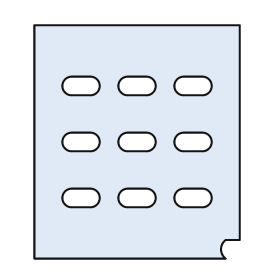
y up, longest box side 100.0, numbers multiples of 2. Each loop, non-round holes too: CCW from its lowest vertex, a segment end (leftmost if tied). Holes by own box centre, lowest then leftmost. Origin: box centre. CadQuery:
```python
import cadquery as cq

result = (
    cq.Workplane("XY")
    .moveTo(-44.0, -50.0)
    .lineTo(38.0, -50.0)
    .threePointArc((36.0, -46.0), (38.0, -42.0))
    .lineTo(44.0, -42.0)
    .lineTo(44.0, 50.0)
    .lineTo(-44.0, 50.0)
    .close()
    .moveTo(-28.0, -28.0)
    .lineTo(-20.0, -28.0)
    .threePointArc((-16.0, -24.0), (-20.0, -20.0))
    .lineTo(-28.0, -20.0)
    .threePointArc((-32.0, -24.0), (-28.0, -28.0))
    .close()
    .moveTo(-4.0, -28.0)
    .lineTo(4.0, -28.0)
    .threePointArc((8.0, -24.0), (4.0, -20.0))
    .lineTo(-4.0, -20.0)
    .threePointArc((-8.0, -24.0), (-4.0, -28.0))
    .close()
    .moveTo(20.0, -28.0)
    .lineTo(28.0, -28.0)
    .threePointArc((32.0, -24.0), (28.0, -20.0))
    .lineTo(20.0, -20.0)
    .threePointArc((16.0, -24.0), (20.0, -28.0))
    .close()
    .moveTo(-28.0, -4.0)
    .lineTo(-20.0, -4.0)
    .threePointArc((-16.0, 0.0), (-20.0, 4.0))
    .lineTo(-28.0, 4.0)
    .threePointArc((-32.0, 0.0), (-28.0, -4.0))
    .close()
    .moveTo(-4.0, -4.0)
    .lineTo(4.0, -4.0)
    .threePointArc((8.0, 0.0), (4.0, 4.0))
    .lineTo(-4.0, 4.0)
    .threePointArc((-8.0, 0.0), (-4.0, -4.0))
    .close()
    .moveTo(20.0, -4.0)
    .lineTo(28.0, -4.0)
    .threePointArc((32.0, 0.0), (28.0, 4.0))
    .lineTo(20.0, 4.0)
    .threePointArc((16.0, 0.0), (20.0, -4.0))
    .close()
    .moveTo(-28.0, 20.0)
    .lineTo(-20.0, 20.0)
    .threePointArc((-16.0, 24.0), (-20.0, 28.0))
    .lineTo(-28.0, 28.0)
    .threePointArc((-32.0, 24.0), (-28.0, 20.0))
    .close()
    .moveTo(-4.0, 20.0)
    .lineTo(4.0, 20.0)
    .threePointArc((8.0, 24.0), (4.0, 28.0))
    .lineTo(-4.0, 28.0)
    .threePointArc((-8.0, 24.0), (-4.0, 20.0))
    .close()
    .moveTo(20.0, 20.0)
    .lineTo(28.0, 20.0)
    .threePointArc((32.0, 24.0), (28.0, 28.0))
    .lineTo(20.0, 28.0)
    .threePointArc((16.0, 24.0), (20.0, 20.0))
    .close()
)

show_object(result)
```